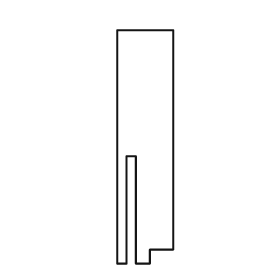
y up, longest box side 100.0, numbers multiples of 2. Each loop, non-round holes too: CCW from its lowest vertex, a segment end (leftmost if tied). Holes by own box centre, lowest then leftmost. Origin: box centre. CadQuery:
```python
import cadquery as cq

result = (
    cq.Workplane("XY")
    .moveTo(-12.0, -50.0)
    .lineTo(-8.0, -50.0)
    .lineTo(-8.0, -4.0)
    .lineTo(-4.0, -4.0)
    .lineTo(-4.0, -50.0)
    .lineTo(2.0, -50.0)
    .lineTo(2.0, -44.0)
    .lineTo(12.0, -44.0)
    .lineTo(12.0, 50.0)
    .lineTo(-12.0, 50.0)
    .close()
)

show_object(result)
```